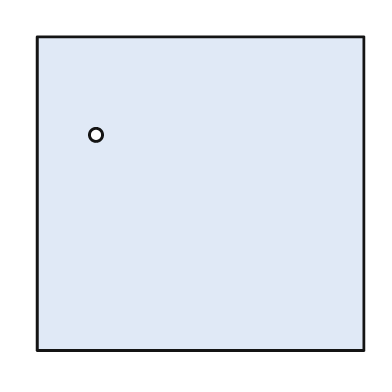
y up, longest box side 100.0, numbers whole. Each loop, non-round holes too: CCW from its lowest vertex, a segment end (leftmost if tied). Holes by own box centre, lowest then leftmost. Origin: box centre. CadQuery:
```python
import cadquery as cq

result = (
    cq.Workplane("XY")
    .moveTo(-50.0, -48.0)
    .lineTo(50.0, -48.0)
    .lineTo(50.0, 48.0)
    .lineTo(-50.0, 48.0)
    .close()
    .moveTo(-32.0, 18.0)
    .circle(2.0)
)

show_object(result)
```